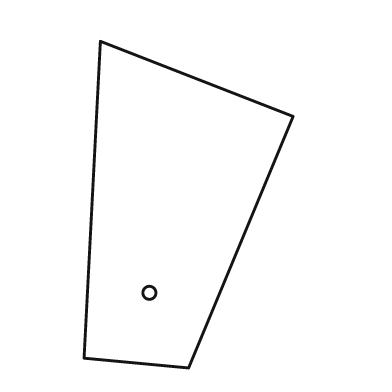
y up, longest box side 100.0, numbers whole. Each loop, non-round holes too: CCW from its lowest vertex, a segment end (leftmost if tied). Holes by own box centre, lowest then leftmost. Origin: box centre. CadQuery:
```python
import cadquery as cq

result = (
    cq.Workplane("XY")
    .moveTo(0.0, -50.0)
    .lineTo(32.0, 27.0)
    .lineTo(-27.0, 50.0)
    .lineTo(-32.0, -47.0)
    .close()
    .moveTo(-12.0, -27.0)
    .circle(2.0)
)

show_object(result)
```